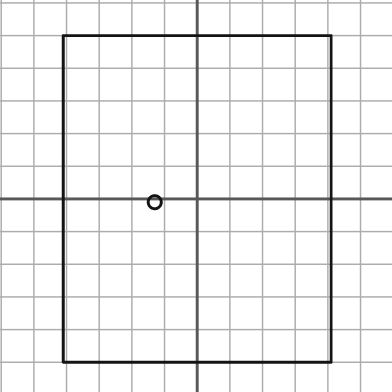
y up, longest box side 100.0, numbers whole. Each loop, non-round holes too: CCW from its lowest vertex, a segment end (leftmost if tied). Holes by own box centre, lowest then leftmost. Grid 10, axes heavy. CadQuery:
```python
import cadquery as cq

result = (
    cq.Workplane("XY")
    .moveTo(-41.0, -50.0)
    .lineTo(41.0, -50.0)
    .lineTo(41.0, 50.0)
    .lineTo(-41.0, 50.0)
    .close()
    .moveTo(-13.0, -1.0)
    .circle(2.0)
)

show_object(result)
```